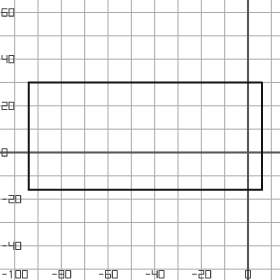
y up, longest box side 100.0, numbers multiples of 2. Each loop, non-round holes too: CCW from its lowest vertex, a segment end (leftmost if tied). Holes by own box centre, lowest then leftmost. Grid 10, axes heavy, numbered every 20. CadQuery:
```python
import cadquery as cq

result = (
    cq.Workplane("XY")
    .moveTo(-94.0, -16.0)
    .lineTo(6.0, -16.0)
    .lineTo(6.0, 30.0)
    .lineTo(-94.0, 30.0)
    .close()
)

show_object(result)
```